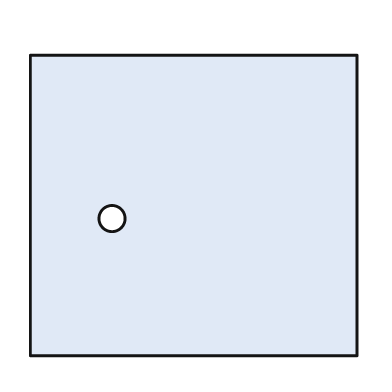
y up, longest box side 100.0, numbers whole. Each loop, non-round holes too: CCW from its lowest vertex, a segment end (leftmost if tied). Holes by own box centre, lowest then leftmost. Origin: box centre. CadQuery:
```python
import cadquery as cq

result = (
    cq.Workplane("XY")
    .moveTo(-50.0, -46.0)
    .lineTo(50.0, -46.0)
    .lineTo(50.0, 46.0)
    .lineTo(-50.0, 46.0)
    .close()
    .moveTo(-25.0, -4.0)
    .circle(4.0)
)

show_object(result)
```